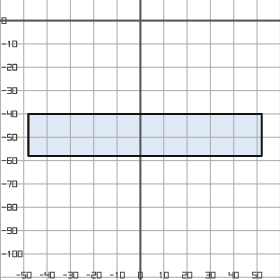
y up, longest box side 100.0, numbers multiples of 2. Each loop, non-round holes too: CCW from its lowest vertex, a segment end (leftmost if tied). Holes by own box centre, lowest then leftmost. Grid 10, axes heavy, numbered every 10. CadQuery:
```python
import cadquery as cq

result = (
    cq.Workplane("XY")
    .moveTo(-48.0, -58.0)
    .lineTo(52.0, -58.0)
    .lineTo(52.0, -40.0)
    .lineTo(-48.0, -40.0)
    .close()
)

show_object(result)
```